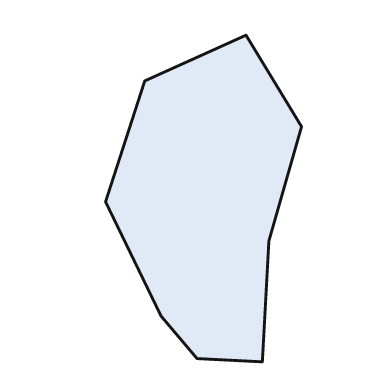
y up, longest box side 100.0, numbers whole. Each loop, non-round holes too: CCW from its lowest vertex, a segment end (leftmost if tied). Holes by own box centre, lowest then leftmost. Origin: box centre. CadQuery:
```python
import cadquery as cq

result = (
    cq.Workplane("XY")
    .moveTo(18.0, -50.0)
    .lineTo(20.0, -13.0)
    .lineTo(30.0, 22.0)
    .lineTo(13.0, 50.0)
    .lineTo(-18.0, 36.0)
    .lineTo(-30.0, -1.0)
    .lineTo(-13.0, -36.0)
    .lineTo(-2.0, -49.0)
    .close()
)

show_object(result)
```